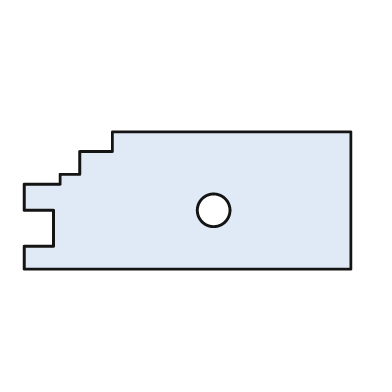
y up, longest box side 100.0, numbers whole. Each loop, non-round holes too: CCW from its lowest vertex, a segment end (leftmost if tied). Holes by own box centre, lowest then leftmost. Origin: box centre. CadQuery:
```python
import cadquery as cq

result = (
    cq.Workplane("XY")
    .moveTo(-50.0, -21.0)
    .lineTo(50.0, -21.0)
    .lineTo(50.0, 21.0)
    .lineTo(-23.0, 21.0)
    .lineTo(-23.0, 15.0)
    .lineTo(-33.0, 15.0)
    .lineTo(-33.0, 8.0)
    .lineTo(-39.0, 8.0)
    .lineTo(-39.0, 5.0)
    .lineTo(-50.0, 5.0)
    .lineTo(-50.0, -3.0)
    .lineTo(-41.0, -3.0)
    .lineTo(-41.0, -14.0)
    .lineTo(-50.0, -14.0)
    .close()
    .moveTo(8.0, -3.0)
    .circle(5.0)
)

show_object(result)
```